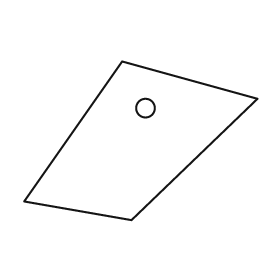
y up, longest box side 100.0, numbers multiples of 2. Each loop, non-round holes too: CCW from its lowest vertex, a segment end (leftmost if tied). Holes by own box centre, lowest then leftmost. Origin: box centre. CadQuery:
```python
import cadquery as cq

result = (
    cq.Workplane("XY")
    .moveTo(-4.0, -34.0)
    .lineTo(50.0, 18.0)
    .lineTo(-8.0, 34.0)
    .lineTo(-50.0, -26.0)
    .close()
    .moveTo(2.0, 14.0)
    .circle(4.0)
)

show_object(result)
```